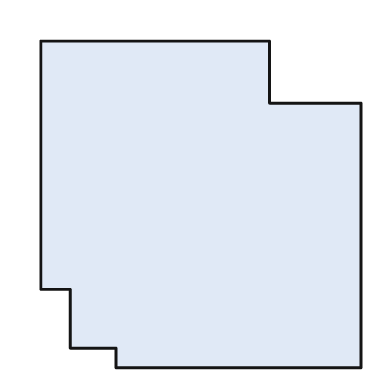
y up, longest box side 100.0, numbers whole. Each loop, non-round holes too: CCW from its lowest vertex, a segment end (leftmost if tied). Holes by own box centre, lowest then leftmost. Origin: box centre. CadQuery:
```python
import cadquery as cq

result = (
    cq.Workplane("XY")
    .moveTo(-26.0, -50.0)
    .lineTo(49.0, -50.0)
    .lineTo(49.0, 31.0)
    .lineTo(21.0, 31.0)
    .lineTo(21.0, 50.0)
    .lineTo(-49.0, 50.0)
    .lineTo(-49.0, -26.0)
    .lineTo(-40.0, -26.0)
    .lineTo(-40.0, -44.0)
    .lineTo(-26.0, -44.0)
    .close()
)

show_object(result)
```